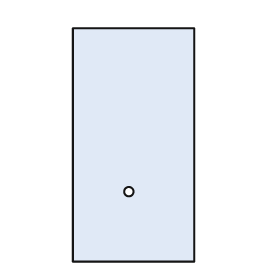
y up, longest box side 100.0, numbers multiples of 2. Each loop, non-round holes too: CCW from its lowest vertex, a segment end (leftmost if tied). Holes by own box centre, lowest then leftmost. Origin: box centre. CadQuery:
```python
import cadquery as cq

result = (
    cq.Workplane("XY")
    .moveTo(-26.0, -50.0)
    .lineTo(26.0, -50.0)
    .lineTo(26.0, 50.0)
    .lineTo(-26.0, 50.0)
    .close()
    .moveTo(-2.0, -20.0)
    .circle(2.0)
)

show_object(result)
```